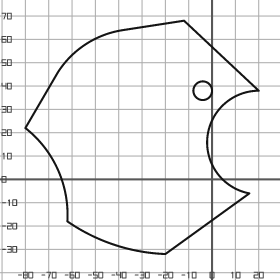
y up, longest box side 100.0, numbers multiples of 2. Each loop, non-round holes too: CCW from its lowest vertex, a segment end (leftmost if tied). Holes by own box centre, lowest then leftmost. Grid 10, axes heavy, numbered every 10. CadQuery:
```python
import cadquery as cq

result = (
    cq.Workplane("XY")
    .moveTo(-20.0, -32.0)
    .lineTo(16.0, -6.0)
    .threePointArc((-2.0, 18.0), (20.0, 38.0))
    .lineTo(-12.0, 68.0)
    .lineTo(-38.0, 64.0)
    .threePointArc((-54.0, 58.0), (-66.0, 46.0))
    .lineTo(-80.0, 22.0)
    .threePointArc((-66.0, 4.0), (-62.0, -18.0))
    .threePointArc((-42.0, -28.0), (-20.0, -32.0))
    .close()
    .moveTo(-4.0, 38.0)
    .circle(4.0)
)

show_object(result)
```